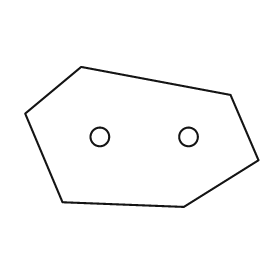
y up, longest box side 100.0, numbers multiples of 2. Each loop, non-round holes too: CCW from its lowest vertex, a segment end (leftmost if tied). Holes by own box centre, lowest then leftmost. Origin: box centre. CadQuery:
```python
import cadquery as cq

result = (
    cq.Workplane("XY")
    .moveTo(18.0, -30.0)
    .lineTo(50.0, -10.0)
    .lineTo(38.0, 18.0)
    .lineTo(-26.0, 30.0)
    .lineTo(-50.0, 10.0)
    .lineTo(-34.0, -28.0)
    .close()
    .moveTo(-18.0, 0.0)
    .circle(4.0)
    .moveTo(20.0, 0.0)
    .circle(4.0)
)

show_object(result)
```